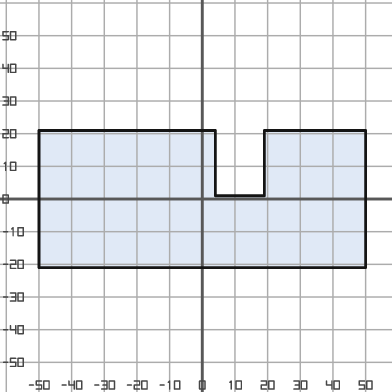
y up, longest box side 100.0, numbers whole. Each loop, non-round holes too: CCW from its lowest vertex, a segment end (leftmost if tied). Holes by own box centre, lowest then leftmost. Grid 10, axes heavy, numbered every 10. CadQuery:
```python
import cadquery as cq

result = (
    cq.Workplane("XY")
    .moveTo(-50.0, -21.0)
    .lineTo(50.0, -21.0)
    .lineTo(50.0, 21.0)
    .lineTo(19.0, 21.0)
    .lineTo(19.0, 1.0)
    .lineTo(4.0, 1.0)
    .lineTo(4.0, 21.0)
    .lineTo(-50.0, 21.0)
    .close()
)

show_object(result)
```